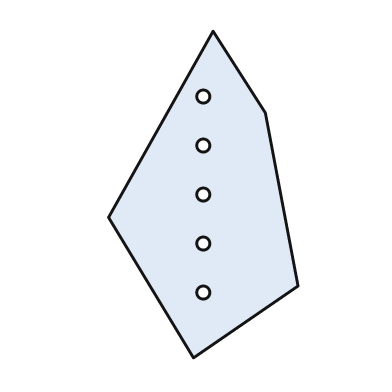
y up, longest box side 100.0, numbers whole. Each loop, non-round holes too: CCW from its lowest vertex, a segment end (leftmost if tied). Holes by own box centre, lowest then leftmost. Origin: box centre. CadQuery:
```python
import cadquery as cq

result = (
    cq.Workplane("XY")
    .moveTo(-3.0, -50.0)
    .lineTo(29.0, -28.0)
    .lineTo(19.0, 25.0)
    .lineTo(3.0, 50.0)
    .lineTo(-29.0, -7.0)
    .close()
    .moveTo(0.0, -30.0)
    .circle(2.0)
    .moveTo(0.0, -15.0)
    .circle(2.0)
    .moveTo(0.0, 0.0)
    .circle(2.0)
    .moveTo(0.0, 15.0)
    .circle(2.0)
    .moveTo(0.0, 30.0)
    .circle(2.0)
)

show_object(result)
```